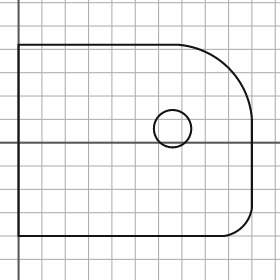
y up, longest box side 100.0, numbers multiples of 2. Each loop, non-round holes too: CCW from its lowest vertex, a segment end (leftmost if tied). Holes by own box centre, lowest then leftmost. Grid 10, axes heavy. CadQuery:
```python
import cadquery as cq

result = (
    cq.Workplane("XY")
    .moveTo(0.0, -40.0)
    .lineTo(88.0, -40.0)
    .threePointArc((96.0, -36.0), (100.0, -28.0))
    .lineTo(100.0, 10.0)
    .threePointArc((90.0, 32.0), (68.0, 42.0))
    .lineTo(0.0, 42.0)
    .close()
    .moveTo(66.0, 6.0)
    .circle(8.0)
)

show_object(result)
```